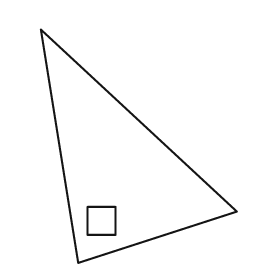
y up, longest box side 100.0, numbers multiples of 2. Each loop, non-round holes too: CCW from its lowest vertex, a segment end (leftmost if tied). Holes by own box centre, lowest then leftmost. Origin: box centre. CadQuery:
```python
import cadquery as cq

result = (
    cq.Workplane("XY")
    .moveTo(-26.0, -50.0)
    .lineTo(42.0, -28.0)
    .lineTo(-42.0, 50.0)
    .close()
    .moveTo(-22.0, -38.0)
    .lineTo(-10.0, -38.0)
    .lineTo(-10.0, -26.0)
    .lineTo(-22.0, -26.0)
    .close()
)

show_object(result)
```